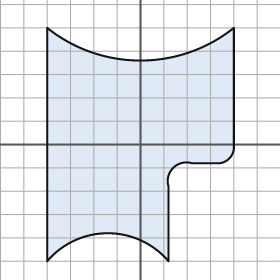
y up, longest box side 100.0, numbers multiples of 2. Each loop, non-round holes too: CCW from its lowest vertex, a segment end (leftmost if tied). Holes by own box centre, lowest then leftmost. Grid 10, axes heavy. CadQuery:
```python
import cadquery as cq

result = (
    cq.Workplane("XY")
    .moveTo(-40.0, -50.0)
    .threePointArc((-14.0, -38.0), (12.0, -50.0))
    .lineTo(12.0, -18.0)
    .threePointArc((14.0, -10.0), (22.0, -8.0))
    .lineTo(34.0, -8.0)
    .threePointArc((38.0, -6.0), (40.0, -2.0))
    .lineTo(40.0, 50.0)
    .threePointArc((0.0, 36.0), (-40.0, 50.0))
    .close()
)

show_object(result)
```